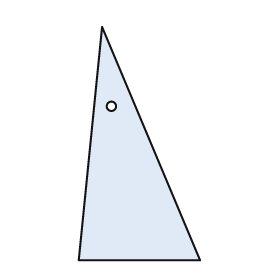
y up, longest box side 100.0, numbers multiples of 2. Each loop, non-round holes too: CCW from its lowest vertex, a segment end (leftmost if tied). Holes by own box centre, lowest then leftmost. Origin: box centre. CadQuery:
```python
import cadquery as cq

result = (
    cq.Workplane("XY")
    .moveTo(-26.0, -50.0)
    .lineTo(26.0, -50.0)
    .lineTo(-16.0, 50.0)
    .close()
    .moveTo(-12.0, 16.0)
    .circle(2.0)
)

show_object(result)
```